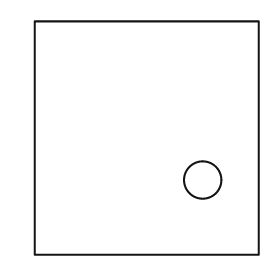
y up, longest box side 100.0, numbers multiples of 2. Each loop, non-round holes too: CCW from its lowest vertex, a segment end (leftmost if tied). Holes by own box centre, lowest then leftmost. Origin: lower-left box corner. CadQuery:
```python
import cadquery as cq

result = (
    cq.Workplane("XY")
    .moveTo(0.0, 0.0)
    .lineTo(96.0, 0.0)
    .lineTo(96.0, 100.0)
    .lineTo(0.0, 100.0)
    .close()
    .moveTo(72.0, 32.0)
    .circle(8.0)
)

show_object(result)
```